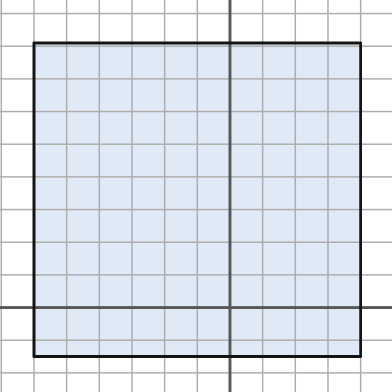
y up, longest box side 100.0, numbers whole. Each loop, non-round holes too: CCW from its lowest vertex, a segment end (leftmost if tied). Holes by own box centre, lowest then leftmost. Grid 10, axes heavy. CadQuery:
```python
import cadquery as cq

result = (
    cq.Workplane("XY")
    .moveTo(-60.0, -15.0)
    .lineTo(40.0, -15.0)
    .lineTo(40.0, 81.0)
    .lineTo(-60.0, 81.0)
    .close()
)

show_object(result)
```